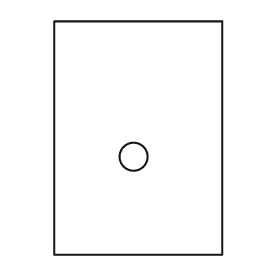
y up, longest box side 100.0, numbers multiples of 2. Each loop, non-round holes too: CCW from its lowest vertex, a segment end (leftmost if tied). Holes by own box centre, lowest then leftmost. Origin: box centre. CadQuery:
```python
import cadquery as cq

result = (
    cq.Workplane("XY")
    .moveTo(-36.0, -50.0)
    .lineTo(36.0, -50.0)
    .lineTo(36.0, 50.0)
    .lineTo(-36.0, 50.0)
    .close()
    .moveTo(-2.0, -8.0)
    .circle(6.0)
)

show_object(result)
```